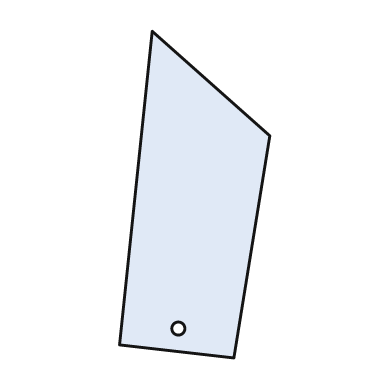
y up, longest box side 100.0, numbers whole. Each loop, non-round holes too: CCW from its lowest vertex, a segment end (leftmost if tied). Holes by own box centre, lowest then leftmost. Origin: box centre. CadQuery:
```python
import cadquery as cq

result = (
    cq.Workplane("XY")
    .moveTo(12.0, -50.0)
    .lineTo(23.0, 18.0)
    .lineTo(-13.0, 50.0)
    .lineTo(-23.0, -46.0)
    .close()
    .moveTo(-5.0, -41.0)
    .circle(2.0)
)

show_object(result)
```